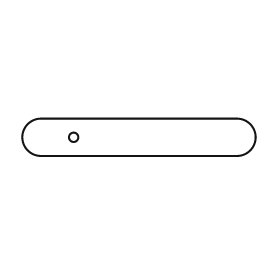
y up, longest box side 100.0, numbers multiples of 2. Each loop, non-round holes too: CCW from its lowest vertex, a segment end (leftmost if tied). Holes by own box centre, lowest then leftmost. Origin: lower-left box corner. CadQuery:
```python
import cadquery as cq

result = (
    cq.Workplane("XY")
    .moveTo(8.0, 0.0)
    .lineTo(92.0, 0.0)
    .threePointArc((100.0, 8.0), (92.0, 16.0))
    .lineTo(8.0, 16.0)
    .threePointArc((0.0, 8.0), (8.0, 0.0))
    .close()
    .moveTo(22.0, 8.0)
    .circle(2.0)
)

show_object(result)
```